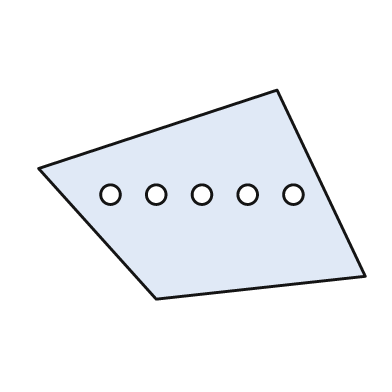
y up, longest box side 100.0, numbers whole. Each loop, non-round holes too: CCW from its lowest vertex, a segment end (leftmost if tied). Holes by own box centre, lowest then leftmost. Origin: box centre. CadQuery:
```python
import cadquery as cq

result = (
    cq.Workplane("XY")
    .moveTo(-14.0, -32.0)
    .lineTo(50.0, -25.0)
    .lineTo(23.0, 32.0)
    .lineTo(-50.0, 8.0)
    .close()
    .moveTo(-28.0, 0.0)
    .circle(3.0)
    .moveTo(-14.0, 0.0)
    .circle(3.0)
    .moveTo(0.0, 0.0)
    .circle(3.0)
    .moveTo(14.0, 0.0)
    .circle(3.0)
    .moveTo(28.0, 0.0)
    .circle(3.0)
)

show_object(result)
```